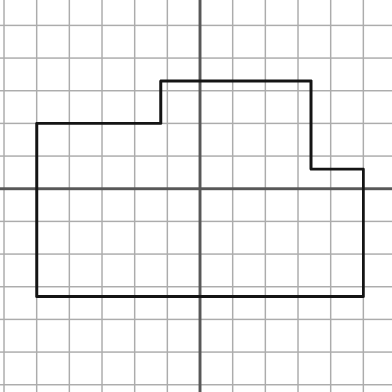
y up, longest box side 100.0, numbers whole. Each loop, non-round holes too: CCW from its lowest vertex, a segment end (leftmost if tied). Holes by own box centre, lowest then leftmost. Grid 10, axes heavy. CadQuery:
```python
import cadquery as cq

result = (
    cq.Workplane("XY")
    .moveTo(-50.0, -33.0)
    .lineTo(50.0, -33.0)
    .lineTo(50.0, 6.0)
    .lineTo(34.0, 6.0)
    .lineTo(34.0, 33.0)
    .lineTo(-12.0, 33.0)
    .lineTo(-12.0, 20.0)
    .lineTo(-50.0, 20.0)
    .close()
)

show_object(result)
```